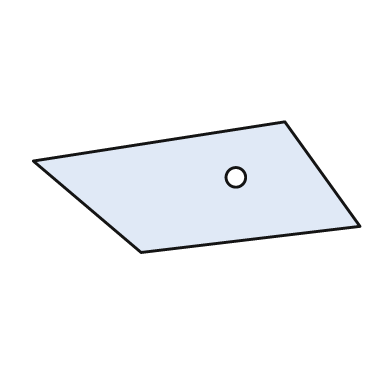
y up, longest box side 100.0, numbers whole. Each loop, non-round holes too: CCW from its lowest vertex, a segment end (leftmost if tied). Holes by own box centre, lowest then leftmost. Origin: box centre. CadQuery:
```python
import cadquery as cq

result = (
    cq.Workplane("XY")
    .moveTo(-17.0, -20.0)
    .lineTo(50.0, -12.0)
    .lineTo(27.0, 20.0)
    .lineTo(-50.0, 8.0)
    .close()
    .moveTo(12.0, 3.0)
    .circle(3.0)
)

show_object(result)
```